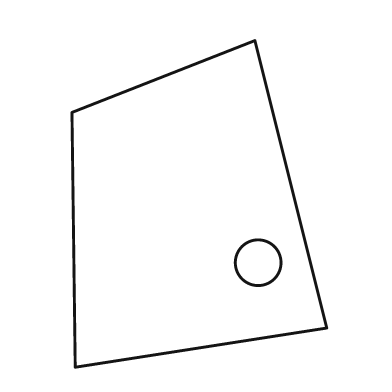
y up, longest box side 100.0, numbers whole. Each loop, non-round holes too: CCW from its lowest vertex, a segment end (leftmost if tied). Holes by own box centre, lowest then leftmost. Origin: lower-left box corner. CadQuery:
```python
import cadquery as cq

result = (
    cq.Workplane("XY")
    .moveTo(1.0, 0.0)
    .lineTo(78.0, 12.0)
    .lineTo(56.0, 100.0)
    .lineTo(0.0, 78.0)
    .close()
    .moveTo(57.0, 32.0)
    .circle(7.0)
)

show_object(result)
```